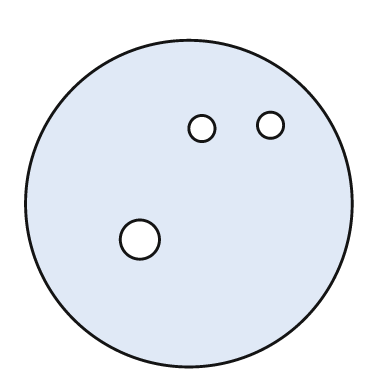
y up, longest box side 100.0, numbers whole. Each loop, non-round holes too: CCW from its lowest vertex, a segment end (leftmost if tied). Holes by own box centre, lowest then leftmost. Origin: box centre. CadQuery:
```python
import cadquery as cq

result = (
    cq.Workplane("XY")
    .moveTo(0.0, 0.0)
    .circle(50.0)
    .moveTo(-15.0, -11.0)
    .circle(6.0)
    .moveTo(4.0, 23.0)
    .circle(4.0)
    .moveTo(25.0, 24.0)
    .circle(4.0)
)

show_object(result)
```